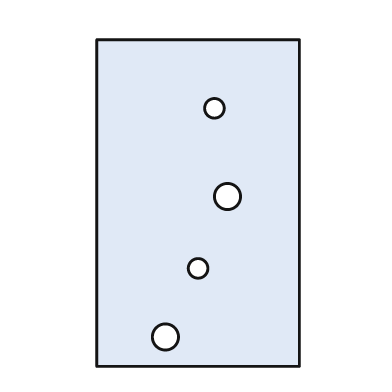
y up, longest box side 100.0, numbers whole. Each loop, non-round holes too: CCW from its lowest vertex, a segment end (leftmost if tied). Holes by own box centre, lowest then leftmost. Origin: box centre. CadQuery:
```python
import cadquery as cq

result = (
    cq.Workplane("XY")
    .moveTo(-31.0, -50.0)
    .lineTo(31.0, -50.0)
    .lineTo(31.0, 50.0)
    .lineTo(-31.0, 50.0)
    .close()
    .moveTo(-10.0, -41.0)
    .circle(4.0)
    .moveTo(0.0, -20.0)
    .circle(3.0)
    .moveTo(9.0, 2.0)
    .circle(4.0)
    .moveTo(5.0, 29.0)
    .circle(3.0)
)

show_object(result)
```